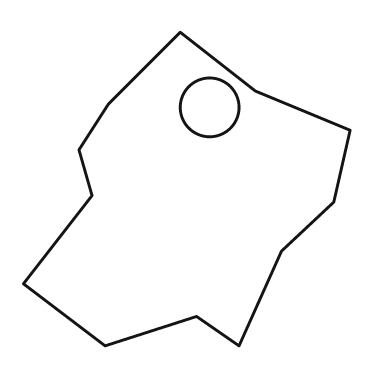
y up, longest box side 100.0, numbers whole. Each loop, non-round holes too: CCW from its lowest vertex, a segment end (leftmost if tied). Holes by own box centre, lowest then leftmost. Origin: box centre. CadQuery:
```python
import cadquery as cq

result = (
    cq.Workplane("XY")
    .moveTo(-25.0, -48.0)
    .lineTo(3.0, -39.0)
    .lineTo(16.0, -48.0)
    .lineTo(29.0, -19.0)
    .lineTo(45.0, -4.0)
    .lineTo(50.0, 18.0)
    .lineTo(21.0, 30.0)
    .lineTo(-2.0, 48.0)
    .lineTo(-24.0, 26.0)
    .lineTo(-33.0, 12.0)
    .lineTo(-29.0, -2.0)
    .lineTo(-50.0, -29.0)
    .close()
    .moveTo(7.0, 25.0)
    .circle(9.0)
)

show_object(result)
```